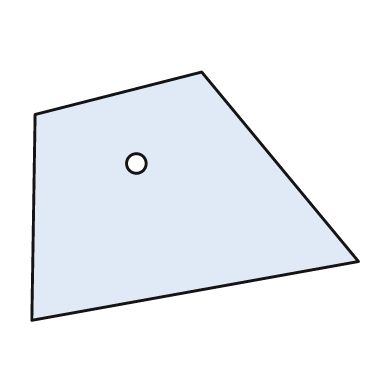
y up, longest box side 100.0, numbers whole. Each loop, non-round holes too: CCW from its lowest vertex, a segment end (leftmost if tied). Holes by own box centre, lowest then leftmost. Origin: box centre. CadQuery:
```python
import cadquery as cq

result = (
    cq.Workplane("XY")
    .moveTo(-50.0, -38.0)
    .lineTo(50.0, -20.0)
    .lineTo(2.0, 38.0)
    .lineTo(-49.0, 25.0)
    .close()
    .moveTo(-18.0, 10.0)
    .circle(3.0)
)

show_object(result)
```